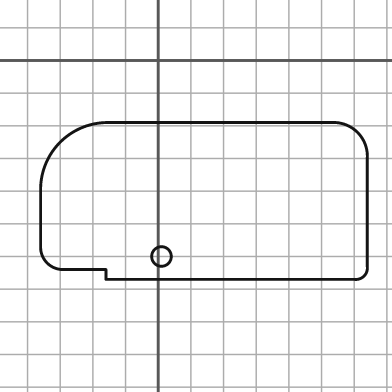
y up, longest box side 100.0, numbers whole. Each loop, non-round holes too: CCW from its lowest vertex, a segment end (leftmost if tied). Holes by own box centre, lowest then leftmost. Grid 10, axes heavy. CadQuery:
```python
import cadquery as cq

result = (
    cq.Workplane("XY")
    .moveTo(-16.0, -67.0)
    .lineTo(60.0, -67.0)
    .threePointArc((63.0, -66.0), (64.0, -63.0))
    .lineTo(64.0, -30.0)
    .threePointArc((61.0, -22.0), (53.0, -19.0))
    .lineTo(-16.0, -19.0)
    .threePointArc((-30.0, -25.0), (-36.0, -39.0))
    .lineTo(-36.0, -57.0)
    .threePointArc((-34.0, -62.0), (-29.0, -64.0))
    .lineTo(-16.0, -64.0)
    .close()
    .moveTo(1.0, -60.0)
    .circle(3.0)
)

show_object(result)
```